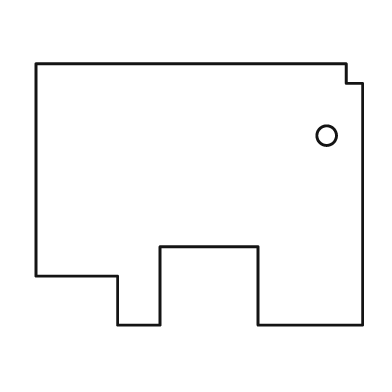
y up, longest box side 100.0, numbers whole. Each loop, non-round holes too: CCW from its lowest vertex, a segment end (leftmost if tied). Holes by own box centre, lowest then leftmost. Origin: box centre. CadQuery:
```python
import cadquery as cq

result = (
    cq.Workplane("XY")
    .moveTo(-25.0, -40.0)
    .lineTo(-12.0, -40.0)
    .lineTo(-12.0, -16.0)
    .lineTo(18.0, -16.0)
    .lineTo(18.0, -40.0)
    .lineTo(50.0, -40.0)
    .lineTo(50.0, 34.0)
    .lineTo(45.0, 34.0)
    .lineTo(45.0, 40.0)
    .lineTo(-50.0, 40.0)
    .lineTo(-50.0, -25.0)
    .lineTo(-25.0, -25.0)
    .close()
    .moveTo(39.0, 18.0)
    .circle(3.0)
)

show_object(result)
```